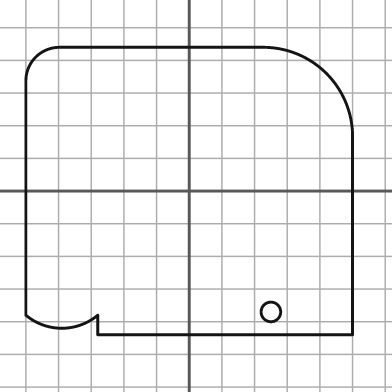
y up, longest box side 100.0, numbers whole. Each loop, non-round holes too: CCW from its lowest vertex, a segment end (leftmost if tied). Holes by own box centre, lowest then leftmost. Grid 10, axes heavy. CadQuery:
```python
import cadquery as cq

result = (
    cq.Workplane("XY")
    .moveTo(-28.0, -44.0)
    .lineTo(50.0, -44.0)
    .lineTo(50.0, 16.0)
    .threePointArc((42.0, 36.0), (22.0, 44.0))
    .lineTo(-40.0, 44.0)
    .threePointArc((-47.0, 41.0), (-50.0, 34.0))
    .lineTo(-50.0, -38.0)
    .threePointArc((-39.0, -42.0), (-28.0, -38.0))
    .close()
    .moveTo(25.0, -37.0)
    .circle(3.0)
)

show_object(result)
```